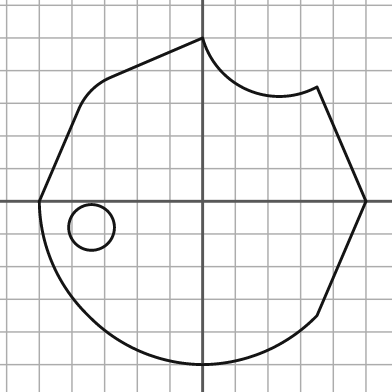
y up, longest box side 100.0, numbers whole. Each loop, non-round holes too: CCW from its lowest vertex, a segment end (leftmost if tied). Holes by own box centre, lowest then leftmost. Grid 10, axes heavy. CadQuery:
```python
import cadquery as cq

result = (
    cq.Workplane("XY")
    .moveTo(0.0, -50.0)
    .threePointArc((19.0, -46.0), (35.0, -35.0))
    .lineTo(50.0, 0.0)
    .lineTo(35.0, 35.0)
    .threePointArc((14.0, 34.0), (0.0, 50.0))
    .lineTo(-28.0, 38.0)
    .threePointArc((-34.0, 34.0), (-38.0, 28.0))
    .lineTo(-50.0, 0.0)
    .threePointArc((-46.0, -19.0), (-35.0, -35.0))
    .threePointArc((-19.0, -46.0), (0.0, -50.0))
    .close()
    .moveTo(-34.0, -8.0)
    .circle(7.0)
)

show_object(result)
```